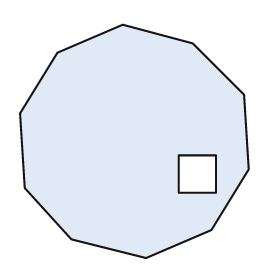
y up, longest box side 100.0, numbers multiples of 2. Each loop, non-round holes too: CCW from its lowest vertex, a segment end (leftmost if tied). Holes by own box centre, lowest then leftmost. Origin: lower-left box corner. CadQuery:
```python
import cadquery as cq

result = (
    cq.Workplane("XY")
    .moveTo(54.0, 0.0)
    .lineTo(82.0, 12.0)
    .lineTo(98.0, 38.0)
    .lineTo(96.0, 70.0)
    .lineTo(74.0, 92.0)
    .lineTo(44.0, 100.0)
    .lineTo(16.0, 88.0)
    .lineTo(0.0, 62.0)
    .lineTo(2.0, 30.0)
    .lineTo(22.0, 8.0)
    .close()
    .moveTo(68.0, 28.0)
    .lineTo(84.0, 28.0)
    .lineTo(84.0, 44.0)
    .lineTo(68.0, 44.0)
    .close()
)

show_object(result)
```